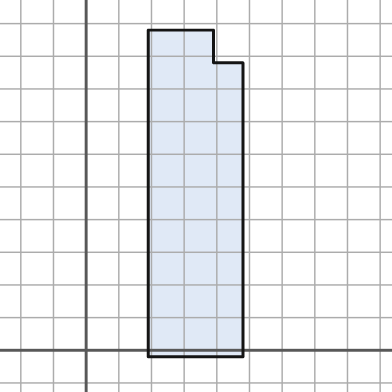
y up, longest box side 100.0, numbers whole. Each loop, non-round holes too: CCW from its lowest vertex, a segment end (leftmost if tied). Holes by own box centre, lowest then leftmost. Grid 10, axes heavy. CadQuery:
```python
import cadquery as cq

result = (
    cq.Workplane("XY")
    .moveTo(19.0, -2.0)
    .lineTo(48.0, -2.0)
    .lineTo(48.0, 88.0)
    .lineTo(39.0, 88.0)
    .lineTo(39.0, 98.0)
    .lineTo(19.0, 98.0)
    .close()
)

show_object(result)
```